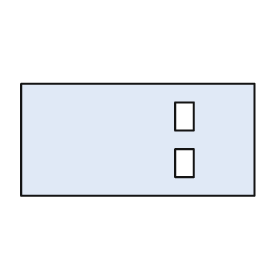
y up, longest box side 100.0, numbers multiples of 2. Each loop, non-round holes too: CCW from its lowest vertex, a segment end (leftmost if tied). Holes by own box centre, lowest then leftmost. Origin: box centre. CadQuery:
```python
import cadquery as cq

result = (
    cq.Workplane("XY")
    .moveTo(-50.0, -24.0)
    .lineTo(50.0, -24.0)
    .lineTo(50.0, 24.0)
    .lineTo(-50.0, 24.0)
    .close()
    .moveTo(16.0, -16.0)
    .lineTo(24.0, -16.0)
    .lineTo(24.0, -4.0)
    .lineTo(16.0, -4.0)
    .close()
    .moveTo(16.0, 4.0)
    .lineTo(24.0, 4.0)
    .lineTo(24.0, 16.0)
    .lineTo(16.0, 16.0)
    .close()
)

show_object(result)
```